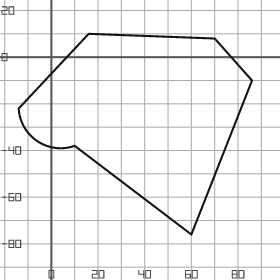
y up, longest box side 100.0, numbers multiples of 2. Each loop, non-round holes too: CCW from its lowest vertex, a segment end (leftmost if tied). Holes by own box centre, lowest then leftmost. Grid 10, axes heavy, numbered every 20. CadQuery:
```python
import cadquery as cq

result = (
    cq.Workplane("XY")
    .moveTo(60.0, -76.0)
    .lineTo(86.0, -10.0)
    .lineTo(70.0, 8.0)
    .lineTo(16.0, 10.0)
    .lineTo(-14.0, -22.0)
    .threePointArc((-6.0, -36.0), (10.0, -38.0))
    .close()
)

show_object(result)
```